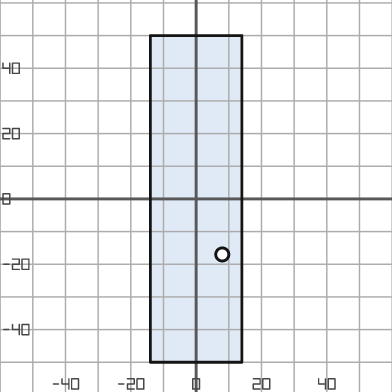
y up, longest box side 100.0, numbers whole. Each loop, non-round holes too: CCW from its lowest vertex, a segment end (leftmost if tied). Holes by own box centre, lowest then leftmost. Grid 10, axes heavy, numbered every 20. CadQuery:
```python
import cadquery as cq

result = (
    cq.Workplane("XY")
    .moveTo(-14.0, -50.0)
    .lineTo(14.0, -50.0)
    .lineTo(14.0, 50.0)
    .lineTo(-14.0, 50.0)
    .close()
    .moveTo(8.0, -17.0)
    .circle(2.0)
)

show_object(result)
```